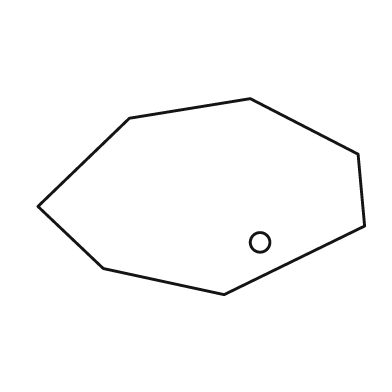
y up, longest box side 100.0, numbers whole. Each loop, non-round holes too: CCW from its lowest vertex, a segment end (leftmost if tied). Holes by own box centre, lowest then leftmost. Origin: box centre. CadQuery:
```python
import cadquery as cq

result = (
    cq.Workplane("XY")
    .moveTo(7.0, -30.0)
    .lineTo(50.0, -9.0)
    .lineTo(48.0, 13.0)
    .lineTo(15.0, 30.0)
    .lineTo(-22.0, 24.0)
    .lineTo(-50.0, -3.0)
    .lineTo(-30.0, -22.0)
    .close()
    .moveTo(18.0, -14.0)
    .circle(3.0)
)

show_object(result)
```